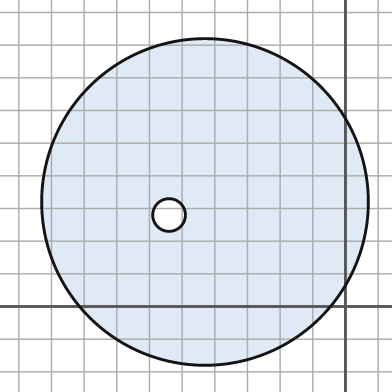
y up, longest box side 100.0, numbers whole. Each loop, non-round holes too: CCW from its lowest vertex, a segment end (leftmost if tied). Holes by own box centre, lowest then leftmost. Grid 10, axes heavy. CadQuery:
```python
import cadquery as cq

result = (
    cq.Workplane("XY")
    .moveTo(-43.0, 32.0)
    .circle(50.0)
    .moveTo(-54.0, 28.0)
    .circle(5.0)
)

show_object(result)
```